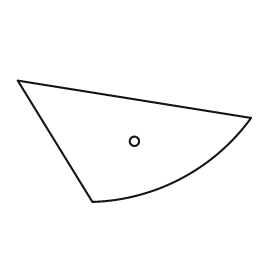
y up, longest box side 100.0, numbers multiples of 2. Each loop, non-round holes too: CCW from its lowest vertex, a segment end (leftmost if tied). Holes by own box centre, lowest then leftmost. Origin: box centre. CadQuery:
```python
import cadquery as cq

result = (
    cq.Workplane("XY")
    .moveTo(-18.0, -26.0)
    .threePointArc((20.0, -16.0), (50.0, 10.0))
    .lineTo(-50.0, 26.0)
    .close()
    .moveTo(0.0, 0.0)
    .circle(2.0)
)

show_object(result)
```